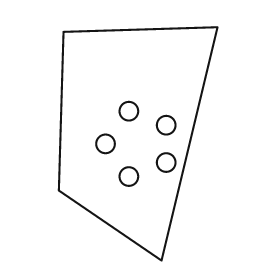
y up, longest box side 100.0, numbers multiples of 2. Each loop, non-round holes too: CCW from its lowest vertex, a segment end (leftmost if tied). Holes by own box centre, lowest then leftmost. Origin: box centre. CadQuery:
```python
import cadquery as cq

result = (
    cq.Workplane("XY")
    .moveTo(10.0, -50.0)
    .lineTo(34.0, 50.0)
    .lineTo(-32.0, 48.0)
    .lineTo(-34.0, -20.0)
    .close()
    .moveTo(-4.0, -14.0)
    .circle(4.0)
    .moveTo(12.0, -8.0)
    .circle(4.0)
    .moveTo(-14.0, 0.0)
    .circle(4.0)
    .moveTo(12.0, 8.0)
    .circle(4.0)
    .moveTo(-4.0, 14.0)
    .circle(4.0)
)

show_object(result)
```